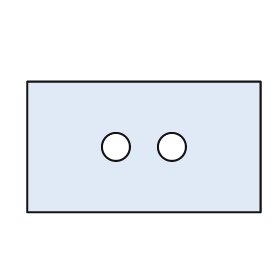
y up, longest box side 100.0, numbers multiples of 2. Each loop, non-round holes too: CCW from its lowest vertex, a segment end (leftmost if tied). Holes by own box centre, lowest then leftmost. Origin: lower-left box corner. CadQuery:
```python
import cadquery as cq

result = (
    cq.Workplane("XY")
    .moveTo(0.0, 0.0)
    .lineTo(100.0, 0.0)
    .lineTo(100.0, 56.0)
    .lineTo(0.0, 56.0)
    .close()
    .moveTo(38.0, 28.0)
    .circle(6.0)
    .moveTo(62.0, 28.0)
    .circle(6.0)
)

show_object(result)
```